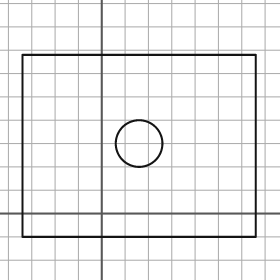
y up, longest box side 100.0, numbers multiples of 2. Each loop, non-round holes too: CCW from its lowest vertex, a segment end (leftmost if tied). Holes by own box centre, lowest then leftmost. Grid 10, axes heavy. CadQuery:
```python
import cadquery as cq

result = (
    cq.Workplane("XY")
    .moveTo(-34.0, -10.0)
    .lineTo(66.0, -10.0)
    .lineTo(66.0, 68.0)
    .lineTo(-34.0, 68.0)
    .close()
    .moveTo(16.0, 30.0)
    .circle(10.0)
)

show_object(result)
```